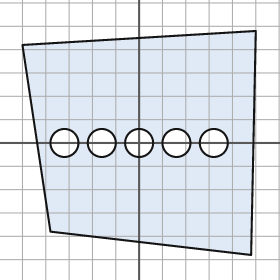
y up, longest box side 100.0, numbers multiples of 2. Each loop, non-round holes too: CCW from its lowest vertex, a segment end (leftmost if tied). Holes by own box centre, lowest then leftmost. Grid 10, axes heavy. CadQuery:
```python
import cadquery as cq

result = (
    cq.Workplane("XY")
    .moveTo(48.0, -48.0)
    .lineTo(50.0, 48.0)
    .lineTo(-50.0, 42.0)
    .lineTo(-38.0, -38.0)
    .close()
    .moveTo(-32.0, 0.0)
    .circle(6.0)
    .moveTo(-16.0, 0.0)
    .circle(6.0)
    .moveTo(0.0, 0.0)
    .circle(6.0)
    .moveTo(16.0, 0.0)
    .circle(6.0)
    .moveTo(32.0, 0.0)
    .circle(6.0)
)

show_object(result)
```